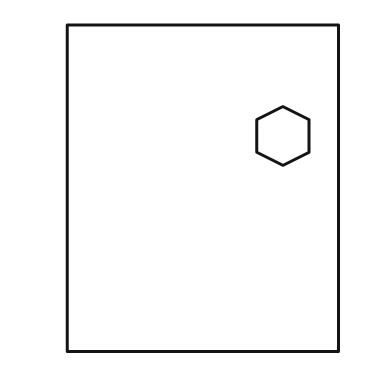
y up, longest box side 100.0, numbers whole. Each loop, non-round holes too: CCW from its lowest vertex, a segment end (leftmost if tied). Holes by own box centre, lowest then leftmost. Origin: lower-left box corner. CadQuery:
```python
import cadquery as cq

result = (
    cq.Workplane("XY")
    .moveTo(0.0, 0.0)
    .lineTo(83.0, 0.0)
    .lineTo(83.0, 100.0)
    .lineTo(0.0, 100.0)
    .close()
    .moveTo(66.0, 57.0)
    .lineTo(74.0, 61.0)
    .lineTo(74.0, 71.0)
    .lineTo(66.0, 75.0)
    .lineTo(58.0, 71.0)
    .lineTo(58.0, 61.0)
    .close()
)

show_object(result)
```